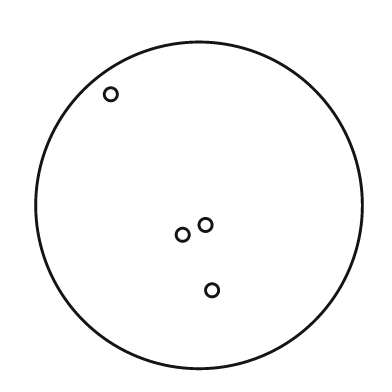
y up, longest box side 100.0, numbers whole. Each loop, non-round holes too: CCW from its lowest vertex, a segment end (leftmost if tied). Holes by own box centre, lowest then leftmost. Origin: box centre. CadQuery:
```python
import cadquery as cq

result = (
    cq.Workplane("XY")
    .moveTo(0.0, 0.0)
    .circle(50.0)
    .moveTo(4.0, -26.0)
    .circle(2.0)
    .moveTo(-5.0, -9.0)
    .circle(2.0)
    .moveTo(2.0, -6.0)
    .circle(2.0)
    .moveTo(-27.0, 34.0)
    .circle(2.0)
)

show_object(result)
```